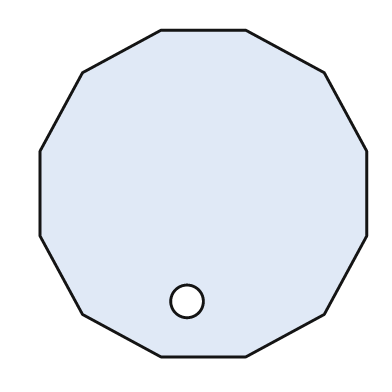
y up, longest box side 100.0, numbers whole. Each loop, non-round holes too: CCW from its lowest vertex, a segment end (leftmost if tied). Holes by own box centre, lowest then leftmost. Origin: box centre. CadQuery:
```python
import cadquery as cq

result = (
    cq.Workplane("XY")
    .moveTo(-13.0, -50.0)
    .lineTo(13.0, -50.0)
    .lineTo(37.0, -37.0)
    .lineTo(50.0, -13.0)
    .lineTo(50.0, 13.0)
    .lineTo(37.0, 37.0)
    .lineTo(13.0, 50.0)
    .lineTo(-13.0, 50.0)
    .lineTo(-37.0, 37.0)
    .lineTo(-50.0, 13.0)
    .lineTo(-50.0, -13.0)
    .lineTo(-37.0, -37.0)
    .close()
    .moveTo(-5.0, -33.0)
    .circle(5.0)
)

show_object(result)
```